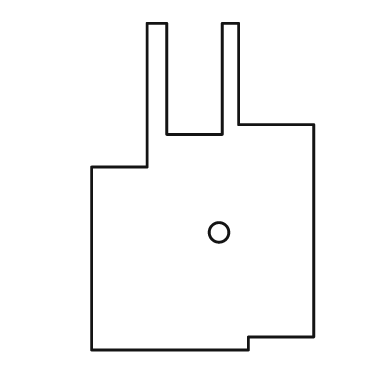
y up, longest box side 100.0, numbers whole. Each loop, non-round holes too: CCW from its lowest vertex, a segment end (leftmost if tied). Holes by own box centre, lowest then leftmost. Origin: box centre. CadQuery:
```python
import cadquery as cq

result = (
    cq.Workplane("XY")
    .moveTo(-34.0, -50.0)
    .lineTo(14.0, -50.0)
    .lineTo(14.0, -46.0)
    .lineTo(34.0, -46.0)
    .lineTo(34.0, 19.0)
    .lineTo(11.0, 19.0)
    .lineTo(11.0, 50.0)
    .lineTo(6.0, 50.0)
    .lineTo(6.0, 16.0)
    .lineTo(-11.0, 16.0)
    .lineTo(-11.0, 50.0)
    .lineTo(-17.0, 50.0)
    .lineTo(-17.0, 6.0)
    .lineTo(-34.0, 6.0)
    .close()
    .moveTo(5.0, -14.0)
    .circle(3.0)
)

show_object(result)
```